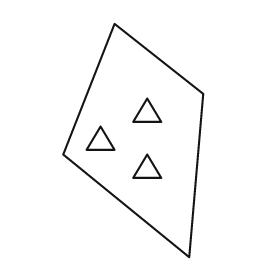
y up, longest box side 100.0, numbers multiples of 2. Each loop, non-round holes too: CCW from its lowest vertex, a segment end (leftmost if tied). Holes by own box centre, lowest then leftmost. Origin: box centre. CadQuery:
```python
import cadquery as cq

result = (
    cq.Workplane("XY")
    .moveTo(24.0, -50.0)
    .lineTo(30.0, 20.0)
    .lineTo(-8.0, 50.0)
    .lineTo(-30.0, -6.0)
    .close()
    .moveTo(0.0, -16.0)
    .lineTo(12.0, -16.0)
    .lineTo(6.0, -6.0)
    .close()
    .moveTo(-20.0, -4.0)
    .lineTo(-8.0, -4.0)
    .lineTo(-14.0, 6.0)
    .close()
    .moveTo(0.0, 8.0)
    .lineTo(12.0, 8.0)
    .lineTo(6.0, 18.0)
    .close()
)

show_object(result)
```